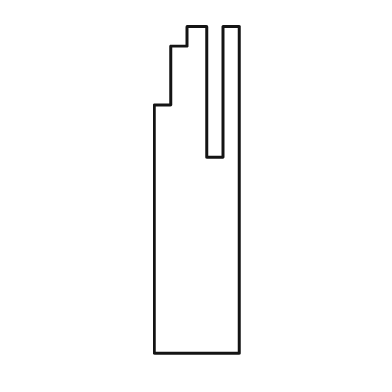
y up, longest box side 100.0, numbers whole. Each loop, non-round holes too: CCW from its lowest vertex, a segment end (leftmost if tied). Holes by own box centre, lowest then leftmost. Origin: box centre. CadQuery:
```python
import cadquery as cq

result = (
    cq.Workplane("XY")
    .moveTo(-13.0, -50.0)
    .lineTo(13.0, -50.0)
    .lineTo(13.0, 50.0)
    .lineTo(8.0, 50.0)
    .lineTo(8.0, 10.0)
    .lineTo(3.0, 10.0)
    .lineTo(3.0, 50.0)
    .lineTo(-3.0, 50.0)
    .lineTo(-3.0, 44.0)
    .lineTo(-8.0, 44.0)
    .lineTo(-8.0, 26.0)
    .lineTo(-13.0, 26.0)
    .close()
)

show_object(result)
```